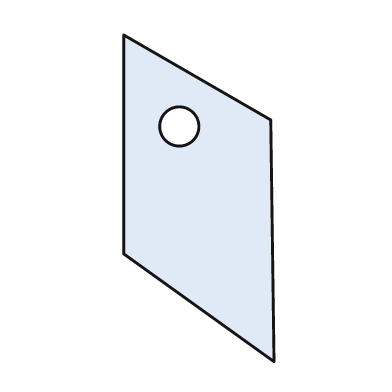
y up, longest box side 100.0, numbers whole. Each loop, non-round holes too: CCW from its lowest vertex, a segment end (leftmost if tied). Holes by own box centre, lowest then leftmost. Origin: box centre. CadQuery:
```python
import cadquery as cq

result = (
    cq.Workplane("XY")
    .moveTo(23.0, -50.0)
    .lineTo(22.0, 24.0)
    .lineTo(-23.0, 50.0)
    .lineTo(-23.0, -17.0)
    .close()
    .moveTo(-6.0, 22.0)
    .circle(6.0)
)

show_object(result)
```